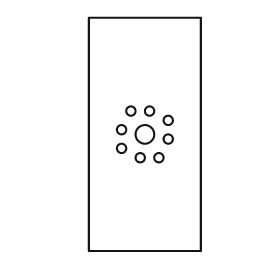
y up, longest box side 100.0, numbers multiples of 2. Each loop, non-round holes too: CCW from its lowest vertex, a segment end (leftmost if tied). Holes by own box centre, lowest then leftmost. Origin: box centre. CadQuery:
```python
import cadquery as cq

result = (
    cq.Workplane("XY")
    .moveTo(-24.0, -50.0)
    .lineTo(24.0, -50.0)
    .lineTo(24.0, 50.0)
    .lineTo(-24.0, 50.0)
    .close()
    .moveTo(-2.0, -10.0)
    .circle(2.0)
    .moveTo(6.0, -10.0)
    .circle(2.0)
    .moveTo(-10.0, -6.0)
    .circle(2.0)
    .moveTo(10.0, -2.0)
    .circle(2.0)
    .moveTo(0.0, 0.0)
    .circle(4.0)
    .moveTo(-10.0, 2.0)
    .circle(2.0)
    .moveTo(10.0, 6.0)
    .circle(2.0)
    .moveTo(-6.0, 10.0)
    .circle(2.0)
    .moveTo(2.0, 10.0)
    .circle(2.0)
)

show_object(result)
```